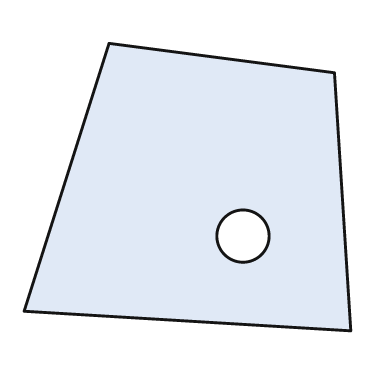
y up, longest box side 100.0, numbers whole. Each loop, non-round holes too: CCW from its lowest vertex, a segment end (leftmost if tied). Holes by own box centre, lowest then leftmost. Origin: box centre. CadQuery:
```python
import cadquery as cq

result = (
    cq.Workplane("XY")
    .moveTo(50.0, -44.0)
    .lineTo(45.0, 35.0)
    .lineTo(-24.0, 44.0)
    .lineTo(-50.0, -38.0)
    .close()
    .moveTo(17.0, -15.0)
    .circle(8.0)
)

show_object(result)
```